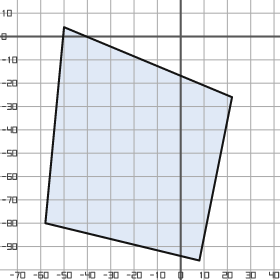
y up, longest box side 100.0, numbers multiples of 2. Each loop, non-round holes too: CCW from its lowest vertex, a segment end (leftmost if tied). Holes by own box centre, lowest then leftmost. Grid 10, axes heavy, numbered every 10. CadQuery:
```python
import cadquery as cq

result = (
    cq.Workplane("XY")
    .moveTo(8.0, -96.0)
    .lineTo(22.0, -26.0)
    .lineTo(-50.0, 4.0)
    .lineTo(-58.0, -80.0)
    .close()
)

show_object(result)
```